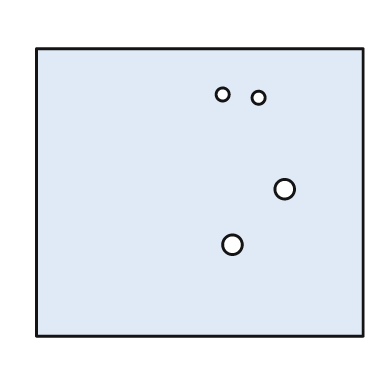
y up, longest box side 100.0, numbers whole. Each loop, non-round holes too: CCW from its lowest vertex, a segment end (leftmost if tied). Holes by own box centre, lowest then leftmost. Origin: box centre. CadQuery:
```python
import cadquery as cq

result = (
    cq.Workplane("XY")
    .moveTo(-50.0, -44.0)
    .lineTo(50.0, -44.0)
    .lineTo(50.0, 44.0)
    .lineTo(-50.0, 44.0)
    .close()
    .moveTo(10.0, -16.0)
    .circle(3.0)
    .moveTo(26.0, 1.0)
    .circle(3.0)
    .moveTo(18.0, 29.0)
    .circle(2.0)
    .moveTo(7.0, 30.0)
    .circle(2.0)
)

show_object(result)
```